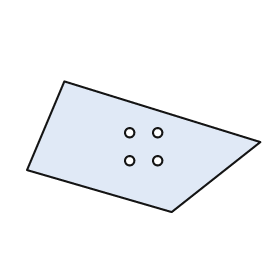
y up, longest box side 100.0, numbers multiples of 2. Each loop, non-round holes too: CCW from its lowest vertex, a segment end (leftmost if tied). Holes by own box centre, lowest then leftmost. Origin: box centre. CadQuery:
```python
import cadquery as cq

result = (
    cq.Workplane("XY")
    .moveTo(12.0, -28.0)
    .lineTo(50.0, 2.0)
    .lineTo(-34.0, 28.0)
    .lineTo(-50.0, -10.0)
    .close()
    .moveTo(-6.0, -6.0)
    .circle(2.0)
    .moveTo(6.0, -6.0)
    .circle(2.0)
    .moveTo(-6.0, 6.0)
    .circle(2.0)
    .moveTo(6.0, 6.0)
    .circle(2.0)
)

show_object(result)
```